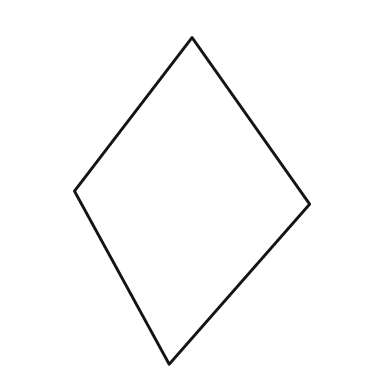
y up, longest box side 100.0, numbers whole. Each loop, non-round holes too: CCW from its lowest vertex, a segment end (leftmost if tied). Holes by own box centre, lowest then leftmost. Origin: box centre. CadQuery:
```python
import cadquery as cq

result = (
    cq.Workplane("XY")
    .moveTo(-7.0, -50.0)
    .lineTo(36.0, -1.0)
    .lineTo(0.0, 50.0)
    .lineTo(-36.0, 3.0)
    .close()
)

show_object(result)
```